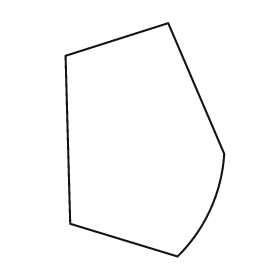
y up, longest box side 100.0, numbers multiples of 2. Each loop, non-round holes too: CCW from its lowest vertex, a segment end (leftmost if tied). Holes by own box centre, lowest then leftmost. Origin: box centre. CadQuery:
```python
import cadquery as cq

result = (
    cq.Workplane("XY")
    .moveTo(14.0, -50.0)
    .threePointArc((28.0, -30.0), (34.0, -6.0))
    .lineTo(10.0, 50.0)
    .lineTo(-34.0, 36.0)
    .lineTo(-32.0, -36.0)
    .close()
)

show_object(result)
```